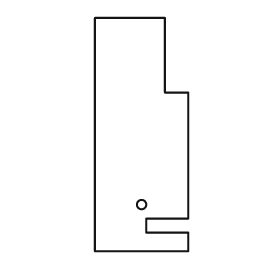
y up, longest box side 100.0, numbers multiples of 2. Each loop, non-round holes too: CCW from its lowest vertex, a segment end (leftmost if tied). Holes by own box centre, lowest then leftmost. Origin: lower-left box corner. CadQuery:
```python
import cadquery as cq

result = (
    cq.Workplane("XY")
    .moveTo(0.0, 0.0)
    .lineTo(40.0, 0.0)
    .lineTo(40.0, 8.0)
    .lineTo(22.0, 8.0)
    .lineTo(22.0, 14.0)
    .lineTo(40.0, 14.0)
    .lineTo(40.0, 68.0)
    .lineTo(30.0, 68.0)
    .lineTo(30.0, 100.0)
    .lineTo(0.0, 100.0)
    .close()
    .moveTo(20.0, 20.0)
    .circle(2.0)
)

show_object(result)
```